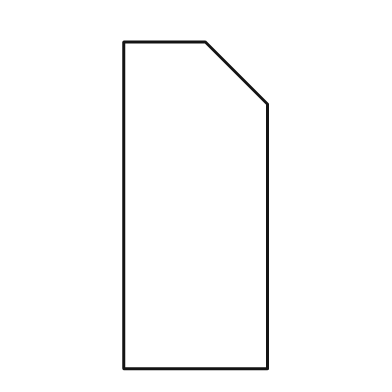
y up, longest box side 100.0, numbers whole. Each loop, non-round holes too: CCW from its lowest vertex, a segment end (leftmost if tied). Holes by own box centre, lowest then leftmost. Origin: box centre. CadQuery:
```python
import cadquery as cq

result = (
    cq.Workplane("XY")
    .moveTo(-22.0, -50.0)
    .lineTo(22.0, -50.0)
    .lineTo(22.0, 31.0)
    .lineTo(3.0, 50.0)
    .lineTo(-22.0, 50.0)
    .close()
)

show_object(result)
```